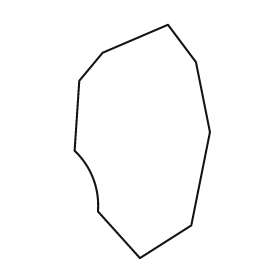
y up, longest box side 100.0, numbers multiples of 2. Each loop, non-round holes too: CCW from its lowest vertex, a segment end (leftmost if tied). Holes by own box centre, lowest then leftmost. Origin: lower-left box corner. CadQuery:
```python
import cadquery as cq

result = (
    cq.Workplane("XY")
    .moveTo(28.0, 0.0)
    .lineTo(50.0, 14.0)
    .lineTo(58.0, 54.0)
    .lineTo(52.0, 84.0)
    .lineTo(40.0, 100.0)
    .lineTo(12.0, 88.0)
    .lineTo(2.0, 76.0)
    .lineTo(0.0, 46.0)
    .threePointArc((8.0, 34.0), (10.0, 20.0))
    .close()
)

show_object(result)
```